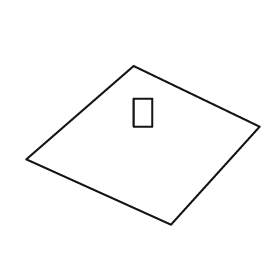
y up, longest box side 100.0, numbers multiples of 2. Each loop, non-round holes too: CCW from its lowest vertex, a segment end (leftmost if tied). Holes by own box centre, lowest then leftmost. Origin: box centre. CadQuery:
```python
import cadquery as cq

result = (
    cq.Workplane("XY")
    .moveTo(12.0, -34.0)
    .lineTo(50.0, 8.0)
    .lineTo(-4.0, 34.0)
    .lineTo(-50.0, -6.0)
    .close()
    .moveTo(-4.0, 8.0)
    .lineTo(4.0, 8.0)
    .lineTo(4.0, 20.0)
    .lineTo(-4.0, 20.0)
    .close()
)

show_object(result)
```